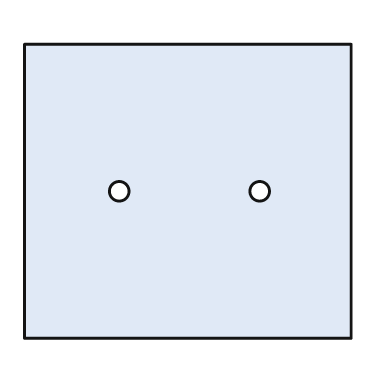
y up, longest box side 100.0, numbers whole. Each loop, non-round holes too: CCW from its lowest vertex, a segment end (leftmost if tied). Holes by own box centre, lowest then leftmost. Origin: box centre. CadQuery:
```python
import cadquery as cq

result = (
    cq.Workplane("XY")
    .moveTo(-50.0, -45.0)
    .lineTo(50.0, -45.0)
    .lineTo(50.0, 45.0)
    .lineTo(-50.0, 45.0)
    .close()
    .moveTo(-21.0, 0.0)
    .circle(3.0)
    .moveTo(22.0, 0.0)
    .circle(3.0)
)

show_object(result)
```